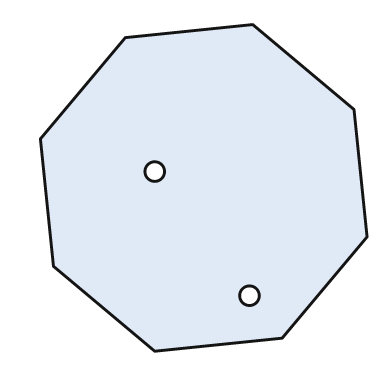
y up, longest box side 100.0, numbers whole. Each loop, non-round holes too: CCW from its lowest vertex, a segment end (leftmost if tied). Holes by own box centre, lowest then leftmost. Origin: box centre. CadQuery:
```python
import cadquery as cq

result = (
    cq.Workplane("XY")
    .moveTo(-15.0, -50.0)
    .lineTo(24.0, -46.0)
    .lineTo(50.0, -15.0)
    .lineTo(46.0, 24.0)
    .lineTo(15.0, 50.0)
    .lineTo(-24.0, 46.0)
    .lineTo(-50.0, 15.0)
    .lineTo(-46.0, -24.0)
    .close()
    .moveTo(14.0, -33.0)
    .circle(3.0)
    .moveTo(-15.0, 5.0)
    .circle(3.0)
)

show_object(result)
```